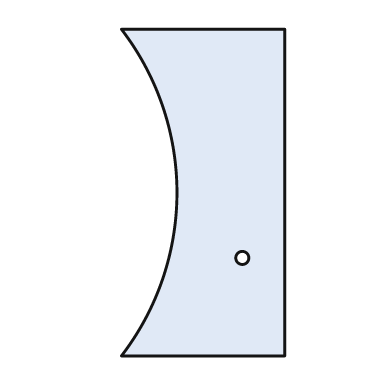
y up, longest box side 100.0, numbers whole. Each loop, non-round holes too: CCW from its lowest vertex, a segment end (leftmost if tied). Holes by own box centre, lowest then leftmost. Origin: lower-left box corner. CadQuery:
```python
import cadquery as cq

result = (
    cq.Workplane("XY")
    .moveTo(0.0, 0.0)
    .lineTo(50.0, 0.0)
    .lineTo(50.0, 100.0)
    .lineTo(0.0, 100.0)
    .threePointArc((17.0, 50.0), (0.0, 0.0))
    .close()
    .moveTo(37.0, 30.0)
    .circle(2.0)
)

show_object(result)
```